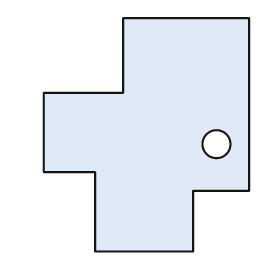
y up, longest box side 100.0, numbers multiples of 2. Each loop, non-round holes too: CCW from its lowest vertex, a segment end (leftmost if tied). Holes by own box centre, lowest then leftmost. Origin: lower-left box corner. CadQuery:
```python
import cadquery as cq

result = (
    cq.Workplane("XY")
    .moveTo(22.0, 0.0)
    .lineTo(64.0, 0.0)
    .lineTo(64.0, 26.0)
    .lineTo(88.0, 26.0)
    .lineTo(88.0, 100.0)
    .lineTo(34.0, 100.0)
    .lineTo(34.0, 68.0)
    .lineTo(0.0, 68.0)
    .lineTo(0.0, 34.0)
    .lineTo(22.0, 34.0)
    .close()
    .moveTo(74.0, 46.0)
    .circle(6.0)
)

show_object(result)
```